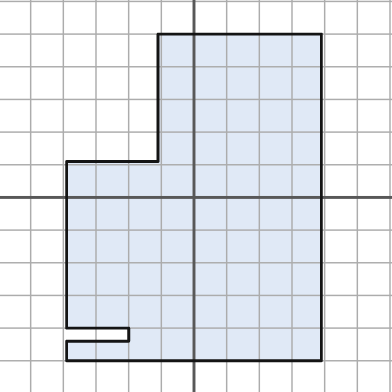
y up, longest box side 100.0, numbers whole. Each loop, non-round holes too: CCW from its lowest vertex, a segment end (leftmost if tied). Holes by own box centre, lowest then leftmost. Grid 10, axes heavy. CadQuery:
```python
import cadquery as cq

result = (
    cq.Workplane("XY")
    .moveTo(-39.0, -50.0)
    .lineTo(39.0, -50.0)
    .lineTo(39.0, 50.0)
    .lineTo(-11.0, 50.0)
    .lineTo(-11.0, 11.0)
    .lineTo(-39.0, 11.0)
    .lineTo(-39.0, -40.0)
    .lineTo(-20.0, -40.0)
    .lineTo(-20.0, -44.0)
    .lineTo(-39.0, -44.0)
    .close()
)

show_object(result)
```